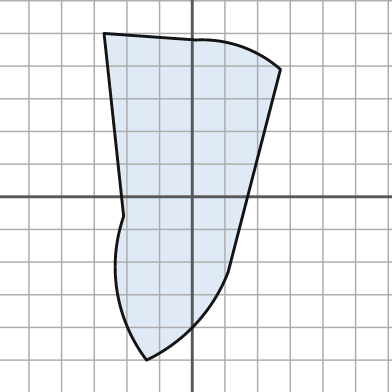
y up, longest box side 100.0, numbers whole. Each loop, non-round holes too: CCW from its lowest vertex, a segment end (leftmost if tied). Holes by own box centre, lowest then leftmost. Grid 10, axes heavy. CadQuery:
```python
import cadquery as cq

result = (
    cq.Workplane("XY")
    .moveTo(-14.0, -50.0)
    .threePointArc((1.0, -39.0), (11.0, -23.0))
    .lineTo(27.0, 39.0)
    .threePointArc((15.0, 46.0), (1.0, 48.0))
    .lineTo(-27.0, 50.0)
    .lineTo(-21.0, -6.0)
    .threePointArc((-23.0, -29.0), (-14.0, -50.0))
    .close()
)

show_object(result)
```